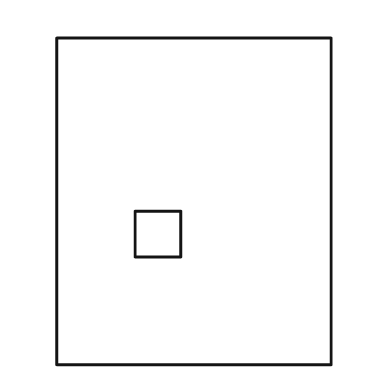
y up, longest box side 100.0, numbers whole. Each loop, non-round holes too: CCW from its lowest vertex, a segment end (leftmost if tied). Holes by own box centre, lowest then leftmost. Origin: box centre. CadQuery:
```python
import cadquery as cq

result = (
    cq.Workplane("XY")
    .moveTo(-42.0, -50.0)
    .lineTo(42.0, -50.0)
    .lineTo(42.0, 50.0)
    .lineTo(-42.0, 50.0)
    .close()
    .moveTo(-18.0, -17.0)
    .lineTo(-4.0, -17.0)
    .lineTo(-4.0, -3.0)
    .lineTo(-18.0, -3.0)
    .close()
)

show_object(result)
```